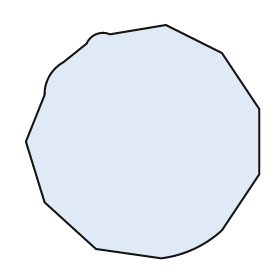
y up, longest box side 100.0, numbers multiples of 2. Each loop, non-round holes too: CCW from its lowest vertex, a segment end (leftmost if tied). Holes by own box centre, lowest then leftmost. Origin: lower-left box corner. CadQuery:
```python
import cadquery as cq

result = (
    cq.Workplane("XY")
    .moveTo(58.0, 0.0)
    .threePointArc((72.0, 4.0), (84.0, 12.0))
    .lineTo(100.0, 36.0)
    .lineTo(100.0, 64.0)
    .lineTo(84.0, 88.0)
    .lineTo(60.0, 100.0)
    .lineTo(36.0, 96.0)
    .threePointArc((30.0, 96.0), (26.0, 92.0))
    .lineTo(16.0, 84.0)
    .threePointArc((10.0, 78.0), (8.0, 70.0))
    .lineTo(0.0, 50.0)
    .lineTo(8.0, 24.0)
    .lineTo(30.0, 4.0)
    .close()
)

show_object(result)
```